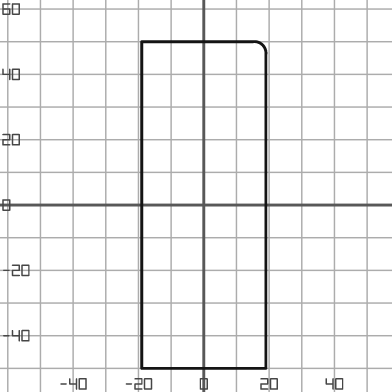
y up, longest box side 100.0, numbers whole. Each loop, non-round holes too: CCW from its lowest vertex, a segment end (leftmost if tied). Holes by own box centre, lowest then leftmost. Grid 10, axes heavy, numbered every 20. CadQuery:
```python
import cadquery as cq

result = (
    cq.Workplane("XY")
    .moveTo(-19.0, -50.0)
    .lineTo(19.0, -50.0)
    .lineTo(19.0, 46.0)
    .threePointArc((18.0, 49.0), (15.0, 50.0))
    .lineTo(-19.0, 50.0)
    .close()
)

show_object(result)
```